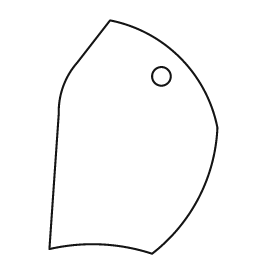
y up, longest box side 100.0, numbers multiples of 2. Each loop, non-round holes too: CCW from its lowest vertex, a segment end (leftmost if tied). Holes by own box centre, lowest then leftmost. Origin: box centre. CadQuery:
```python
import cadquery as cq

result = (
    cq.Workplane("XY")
    .moveTo(8.0, -50.0)
    .threePointArc((28.0, -26.0), (36.0, 4.0))
    .threePointArc((20.0, 34.0), (-10.0, 50.0))
    .lineTo(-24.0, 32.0)
    .threePointArc((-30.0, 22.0), (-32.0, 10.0))
    .lineTo(-36.0, -48.0)
    .threePointArc((-14.0, -46.0), (8.0, -50.0))
    .close()
    .moveTo(12.0, 26.0)
    .circle(4.0)
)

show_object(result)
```